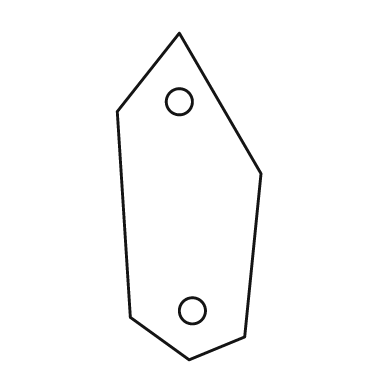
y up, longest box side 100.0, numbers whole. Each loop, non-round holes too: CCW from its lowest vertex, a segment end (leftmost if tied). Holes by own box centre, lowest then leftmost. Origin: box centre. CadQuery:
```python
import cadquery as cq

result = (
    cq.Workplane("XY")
    .moveTo(0.0, -50.0)
    .lineTo(17.0, -43.0)
    .lineTo(22.0, 7.0)
    .lineTo(-3.0, 50.0)
    .lineTo(-22.0, 26.0)
    .lineTo(-18.0, -37.0)
    .close()
    .moveTo(1.0, -35.0)
    .circle(4.0)
    .moveTo(-3.0, 29.0)
    .circle(4.0)
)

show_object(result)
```